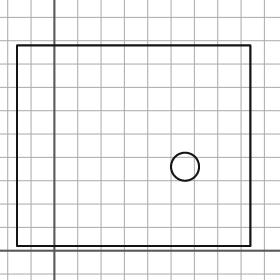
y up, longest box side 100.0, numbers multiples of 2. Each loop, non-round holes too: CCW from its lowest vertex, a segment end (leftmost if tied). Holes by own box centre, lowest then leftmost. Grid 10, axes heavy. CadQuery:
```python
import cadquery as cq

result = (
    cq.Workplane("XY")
    .moveTo(-16.0, 2.0)
    .lineTo(84.0, 2.0)
    .lineTo(84.0, 88.0)
    .lineTo(-16.0, 88.0)
    .close()
    .moveTo(56.0, 36.0)
    .circle(6.0)
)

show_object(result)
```